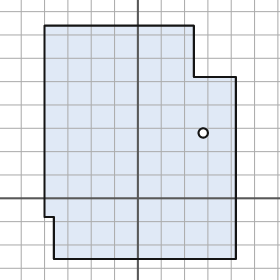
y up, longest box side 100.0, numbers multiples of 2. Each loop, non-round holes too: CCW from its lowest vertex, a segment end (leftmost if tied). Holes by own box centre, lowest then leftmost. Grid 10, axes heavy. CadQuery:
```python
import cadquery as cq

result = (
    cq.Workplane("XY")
    .moveTo(-36.0, -26.0)
    .lineTo(42.0, -26.0)
    .lineTo(42.0, 52.0)
    .lineTo(24.0, 52.0)
    .lineTo(24.0, 74.0)
    .lineTo(-40.0, 74.0)
    .lineTo(-40.0, -8.0)
    .lineTo(-36.0, -8.0)
    .close()
    .moveTo(28.0, 28.0)
    .circle(2.0)
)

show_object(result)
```